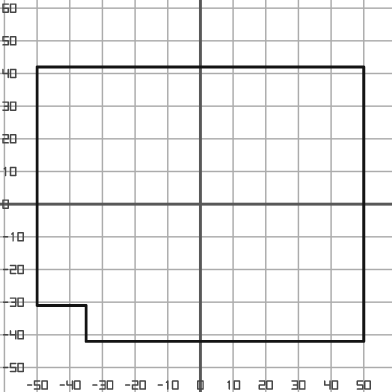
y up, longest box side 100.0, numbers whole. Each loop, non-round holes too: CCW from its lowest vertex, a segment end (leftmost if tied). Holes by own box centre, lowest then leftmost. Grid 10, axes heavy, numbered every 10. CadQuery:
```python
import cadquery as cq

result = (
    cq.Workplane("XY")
    .moveTo(-35.0, -42.0)
    .lineTo(50.0, -42.0)
    .lineTo(50.0, 42.0)
    .lineTo(-50.0, 42.0)
    .lineTo(-50.0, -31.0)
    .lineTo(-35.0, -31.0)
    .close()
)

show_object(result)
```